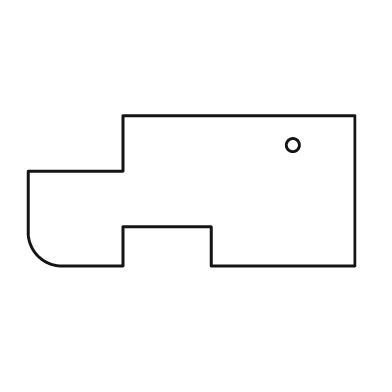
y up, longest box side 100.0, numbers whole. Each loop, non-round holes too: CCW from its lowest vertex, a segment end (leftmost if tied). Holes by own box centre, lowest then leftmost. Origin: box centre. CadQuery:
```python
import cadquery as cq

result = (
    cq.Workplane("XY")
    .moveTo(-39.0, -23.0)
    .lineTo(-21.0, -23.0)
    .lineTo(-21.0, -11.0)
    .lineTo(6.0, -11.0)
    .lineTo(6.0, -23.0)
    .lineTo(50.0, -23.0)
    .lineTo(50.0, 23.0)
    .lineTo(-21.0, 23.0)
    .lineTo(-21.0, 6.0)
    .lineTo(-50.0, 6.0)
    .lineTo(-50.0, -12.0)
    .threePointArc((-47.0, -20.0), (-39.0, -23.0))
    .close()
    .moveTo(31.0, 14.0)
    .circle(2.0)
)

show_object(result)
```